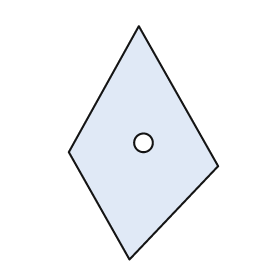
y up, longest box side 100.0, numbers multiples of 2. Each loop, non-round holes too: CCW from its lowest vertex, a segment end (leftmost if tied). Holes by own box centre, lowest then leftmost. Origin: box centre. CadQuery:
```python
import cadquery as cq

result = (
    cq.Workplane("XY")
    .moveTo(-6.0, -50.0)
    .lineTo(32.0, -10.0)
    .lineTo(-2.0, 50.0)
    .lineTo(-32.0, -4.0)
    .close()
    .moveTo(0.0, 0.0)
    .circle(4.0)
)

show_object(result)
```